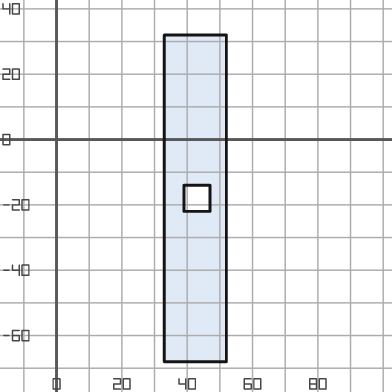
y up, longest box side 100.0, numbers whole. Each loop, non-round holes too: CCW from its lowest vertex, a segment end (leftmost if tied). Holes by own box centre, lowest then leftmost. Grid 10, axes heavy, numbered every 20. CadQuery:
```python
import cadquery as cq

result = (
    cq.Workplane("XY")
    .moveTo(33.0, -68.0)
    .lineTo(52.0, -68.0)
    .lineTo(52.0, 32.0)
    .lineTo(33.0, 32.0)
    .close()
    .moveTo(39.0, -22.0)
    .lineTo(47.0, -22.0)
    .lineTo(47.0, -14.0)
    .lineTo(39.0, -14.0)
    .close()
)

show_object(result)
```